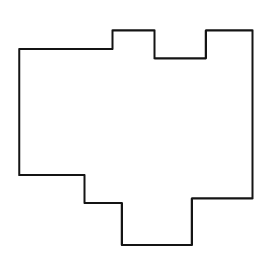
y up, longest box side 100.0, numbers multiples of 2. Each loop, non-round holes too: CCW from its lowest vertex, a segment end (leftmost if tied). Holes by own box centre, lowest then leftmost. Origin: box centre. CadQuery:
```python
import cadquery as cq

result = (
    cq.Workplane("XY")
    .moveTo(-6.0, -46.0)
    .lineTo(24.0, -46.0)
    .lineTo(24.0, -26.0)
    .lineTo(50.0, -26.0)
    .lineTo(50.0, 46.0)
    .lineTo(30.0, 46.0)
    .lineTo(30.0, 34.0)
    .lineTo(8.0, 34.0)
    .lineTo(8.0, 46.0)
    .lineTo(-10.0, 46.0)
    .lineTo(-10.0, 38.0)
    .lineTo(-50.0, 38.0)
    .lineTo(-50.0, -16.0)
    .lineTo(-22.0, -16.0)
    .lineTo(-22.0, -28.0)
    .lineTo(-6.0, -28.0)
    .close()
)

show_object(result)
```